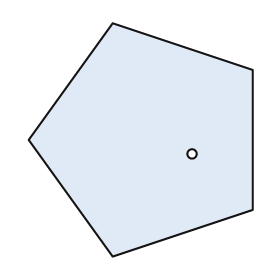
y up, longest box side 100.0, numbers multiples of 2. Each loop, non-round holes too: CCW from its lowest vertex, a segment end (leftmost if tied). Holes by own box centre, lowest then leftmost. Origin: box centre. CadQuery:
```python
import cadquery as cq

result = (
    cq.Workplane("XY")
    .moveTo(-12.0, -50.0)
    .lineTo(48.0, -30.0)
    .lineTo(48.0, 30.0)
    .lineTo(-12.0, 50.0)
    .lineTo(-48.0, 0.0)
    .close()
    .moveTo(22.0, -6.0)
    .circle(2.0)
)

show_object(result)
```